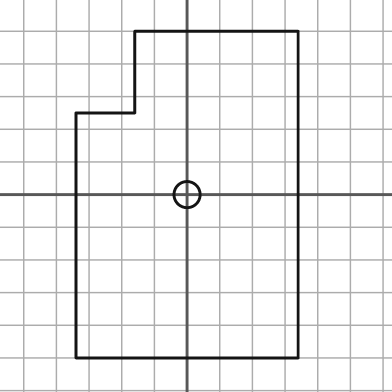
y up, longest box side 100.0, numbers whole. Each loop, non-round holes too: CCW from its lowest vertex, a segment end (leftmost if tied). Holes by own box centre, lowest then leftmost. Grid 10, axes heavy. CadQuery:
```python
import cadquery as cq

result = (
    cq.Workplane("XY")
    .moveTo(-34.0, -50.0)
    .lineTo(34.0, -50.0)
    .lineTo(34.0, 50.0)
    .lineTo(-16.0, 50.0)
    .lineTo(-16.0, 25.0)
    .lineTo(-34.0, 25.0)
    .close()
    .moveTo(0.0, 0.0)
    .circle(4.0)
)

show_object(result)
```